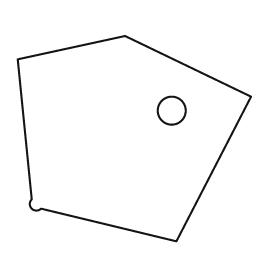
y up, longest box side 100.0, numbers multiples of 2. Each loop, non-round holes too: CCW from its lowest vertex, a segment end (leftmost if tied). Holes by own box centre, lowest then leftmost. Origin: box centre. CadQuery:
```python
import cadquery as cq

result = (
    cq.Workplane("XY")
    .moveTo(18.0, -44.0)
    .lineTo(50.0, 18.0)
    .lineTo(-4.0, 44.0)
    .lineTo(-50.0, 34.0)
    .lineTo(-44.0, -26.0)
    .threePointArc((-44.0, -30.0), (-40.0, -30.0))
    .close()
    .moveTo(16.0, 12.0)
    .circle(6.0)
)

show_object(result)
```